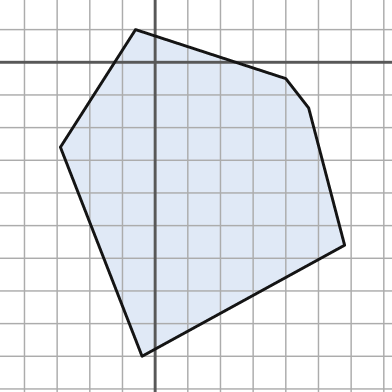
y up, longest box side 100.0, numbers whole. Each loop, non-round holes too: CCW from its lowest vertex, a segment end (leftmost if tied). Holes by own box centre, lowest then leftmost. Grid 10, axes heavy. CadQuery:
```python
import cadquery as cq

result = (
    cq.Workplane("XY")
    .moveTo(-4.0, -90.0)
    .lineTo(58.0, -56.0)
    .lineTo(47.0, -14.0)
    .lineTo(40.0, -5.0)
    .lineTo(-6.0, 10.0)
    .lineTo(-29.0, -26.0)
    .close()
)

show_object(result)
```